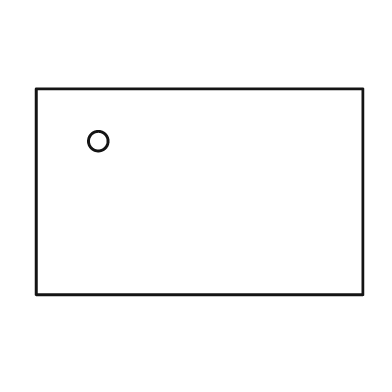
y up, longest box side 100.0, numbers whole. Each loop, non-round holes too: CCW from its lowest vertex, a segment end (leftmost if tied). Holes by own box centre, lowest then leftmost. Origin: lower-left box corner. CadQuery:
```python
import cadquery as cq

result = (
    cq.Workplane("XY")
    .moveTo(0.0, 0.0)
    .lineTo(100.0, 0.0)
    .lineTo(100.0, 63.0)
    .lineTo(0.0, 63.0)
    .close()
    .moveTo(19.0, 47.0)
    .circle(3.0)
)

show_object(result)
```